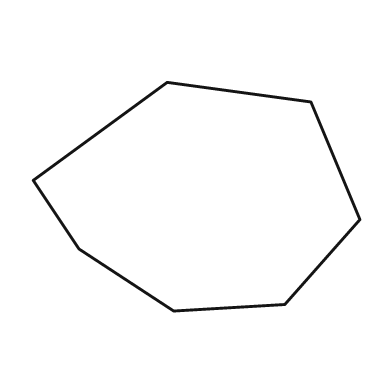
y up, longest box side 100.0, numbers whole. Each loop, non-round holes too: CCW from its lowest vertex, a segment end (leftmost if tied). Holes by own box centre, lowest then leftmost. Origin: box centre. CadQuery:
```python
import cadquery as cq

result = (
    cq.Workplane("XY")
    .moveTo(-7.0, -35.0)
    .lineTo(27.0, -33.0)
    .lineTo(50.0, -7.0)
    .lineTo(35.0, 29.0)
    .lineTo(-9.0, 35.0)
    .lineTo(-50.0, 5.0)
    .lineTo(-36.0, -16.0)
    .close()
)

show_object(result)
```